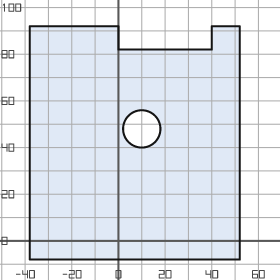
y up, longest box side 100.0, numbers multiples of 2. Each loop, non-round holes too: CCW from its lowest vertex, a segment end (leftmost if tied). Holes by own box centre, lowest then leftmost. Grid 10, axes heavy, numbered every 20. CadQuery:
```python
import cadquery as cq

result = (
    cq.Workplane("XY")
    .moveTo(-38.0, -8.0)
    .lineTo(52.0, -8.0)
    .lineTo(52.0, 92.0)
    .lineTo(40.0, 92.0)
    .lineTo(40.0, 82.0)
    .lineTo(0.0, 82.0)
    .lineTo(0.0, 92.0)
    .lineTo(-38.0, 92.0)
    .close()
    .moveTo(10.0, 48.0)
    .circle(8.0)
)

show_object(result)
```